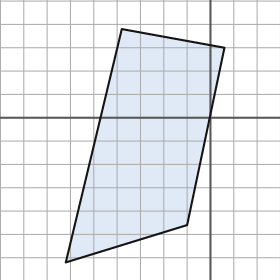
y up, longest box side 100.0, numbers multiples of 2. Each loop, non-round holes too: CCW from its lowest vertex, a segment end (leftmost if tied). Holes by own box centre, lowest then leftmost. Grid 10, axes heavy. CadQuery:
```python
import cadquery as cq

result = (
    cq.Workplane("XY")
    .moveTo(-62.0, -62.0)
    .lineTo(-10.0, -46.0)
    .lineTo(6.0, 30.0)
    .lineTo(-38.0, 38.0)
    .close()
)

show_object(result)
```